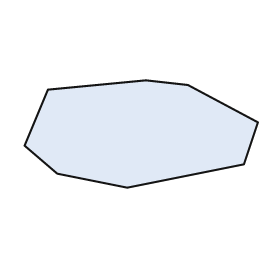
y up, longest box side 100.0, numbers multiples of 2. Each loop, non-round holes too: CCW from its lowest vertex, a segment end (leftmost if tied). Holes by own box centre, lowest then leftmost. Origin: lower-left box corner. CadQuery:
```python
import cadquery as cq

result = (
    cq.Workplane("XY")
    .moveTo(44.0, 0.0)
    .lineTo(94.0, 10.0)
    .lineTo(100.0, 28.0)
    .lineTo(70.0, 44.0)
    .lineTo(52.0, 46.0)
    .lineTo(10.0, 42.0)
    .lineTo(0.0, 18.0)
    .lineTo(14.0, 6.0)
    .close()
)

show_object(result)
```